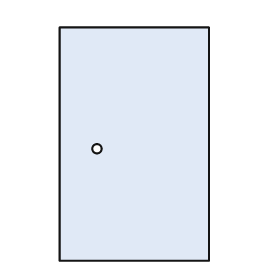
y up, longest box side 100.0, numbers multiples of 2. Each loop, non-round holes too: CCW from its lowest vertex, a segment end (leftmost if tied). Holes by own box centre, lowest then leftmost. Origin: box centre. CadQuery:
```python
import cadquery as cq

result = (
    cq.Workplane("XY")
    .moveTo(-32.0, -50.0)
    .lineTo(32.0, -50.0)
    .lineTo(32.0, 50.0)
    .lineTo(-32.0, 50.0)
    .close()
    .moveTo(-16.0, -2.0)
    .circle(2.0)
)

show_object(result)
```